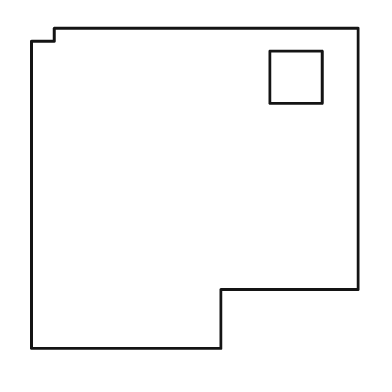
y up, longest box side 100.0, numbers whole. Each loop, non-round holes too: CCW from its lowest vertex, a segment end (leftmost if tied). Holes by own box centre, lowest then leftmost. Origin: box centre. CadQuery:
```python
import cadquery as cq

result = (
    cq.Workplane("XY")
    .moveTo(-50.0, -49.0)
    .lineTo(8.0, -49.0)
    .lineTo(8.0, -31.0)
    .lineTo(50.0, -31.0)
    .lineTo(50.0, 49.0)
    .lineTo(-43.0, 49.0)
    .lineTo(-43.0, 45.0)
    .lineTo(-50.0, 45.0)
    .close()
    .moveTo(23.0, 26.0)
    .lineTo(39.0, 26.0)
    .lineTo(39.0, 42.0)
    .lineTo(23.0, 42.0)
    .close()
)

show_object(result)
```